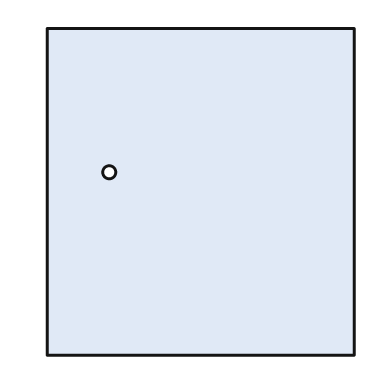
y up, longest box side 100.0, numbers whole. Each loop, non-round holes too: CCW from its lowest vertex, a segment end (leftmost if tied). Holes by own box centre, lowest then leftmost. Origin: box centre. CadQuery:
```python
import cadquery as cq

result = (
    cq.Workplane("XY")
    .moveTo(-47.0, -50.0)
    .lineTo(47.0, -50.0)
    .lineTo(47.0, 50.0)
    .lineTo(-47.0, 50.0)
    .close()
    .moveTo(-28.0, 6.0)
    .circle(2.0)
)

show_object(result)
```